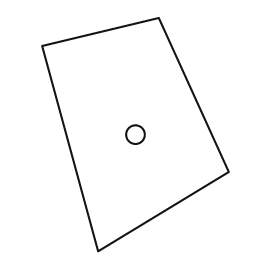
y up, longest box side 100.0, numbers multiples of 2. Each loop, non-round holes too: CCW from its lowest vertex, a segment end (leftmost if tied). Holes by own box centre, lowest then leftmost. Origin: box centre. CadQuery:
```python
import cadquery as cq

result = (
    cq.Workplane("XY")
    .moveTo(-16.0, -50.0)
    .lineTo(40.0, -16.0)
    .lineTo(10.0, 50.0)
    .lineTo(-40.0, 38.0)
    .close()
    .moveTo(0.0, 0.0)
    .circle(4.0)
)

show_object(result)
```